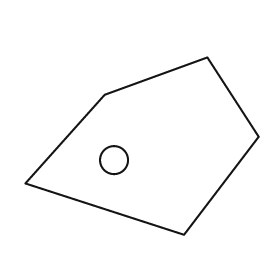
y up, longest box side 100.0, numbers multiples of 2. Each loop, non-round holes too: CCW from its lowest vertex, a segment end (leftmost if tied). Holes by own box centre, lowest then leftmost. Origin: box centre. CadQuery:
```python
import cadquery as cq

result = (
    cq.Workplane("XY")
    .moveTo(18.0, -38.0)
    .lineTo(50.0, 4.0)
    .lineTo(28.0, 38.0)
    .lineTo(-16.0, 22.0)
    .lineTo(-50.0, -16.0)
    .close()
    .moveTo(-12.0, -6.0)
    .circle(6.0)
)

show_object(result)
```